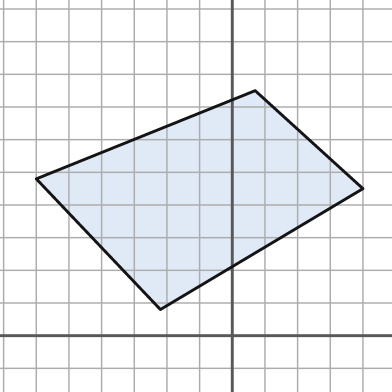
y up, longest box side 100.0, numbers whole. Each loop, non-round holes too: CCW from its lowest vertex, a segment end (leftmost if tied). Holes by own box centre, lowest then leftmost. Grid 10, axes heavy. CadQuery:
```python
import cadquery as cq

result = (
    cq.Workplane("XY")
    .moveTo(-22.0, 8.0)
    .lineTo(40.0, 45.0)
    .lineTo(7.0, 75.0)
    .lineTo(-60.0, 48.0)
    .close()
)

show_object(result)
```